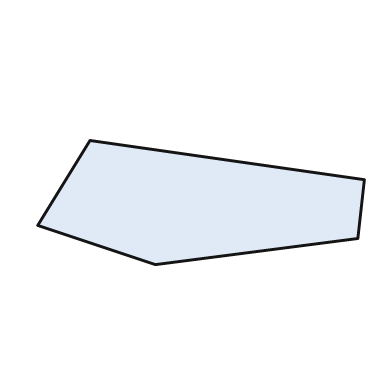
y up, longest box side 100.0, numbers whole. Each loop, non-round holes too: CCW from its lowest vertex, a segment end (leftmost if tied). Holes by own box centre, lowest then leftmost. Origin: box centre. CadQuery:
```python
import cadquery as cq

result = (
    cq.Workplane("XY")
    .moveTo(-14.0, -19.0)
    .lineTo(48.0, -11.0)
    .lineTo(50.0, 7.0)
    .lineTo(-34.0, 19.0)
    .lineTo(-50.0, -7.0)
    .close()
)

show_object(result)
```